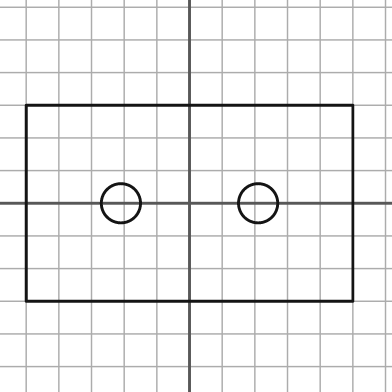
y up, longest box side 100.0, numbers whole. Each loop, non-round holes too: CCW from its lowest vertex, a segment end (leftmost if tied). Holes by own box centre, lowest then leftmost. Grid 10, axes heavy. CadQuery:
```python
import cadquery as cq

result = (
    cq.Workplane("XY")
    .moveTo(-50.0, -30.0)
    .lineTo(50.0, -30.0)
    .lineTo(50.0, 30.0)
    .lineTo(-50.0, 30.0)
    .close()
    .moveTo(-21.0, 0.0)
    .circle(6.0)
    .moveTo(21.0, 0.0)
    .circle(6.0)
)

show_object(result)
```